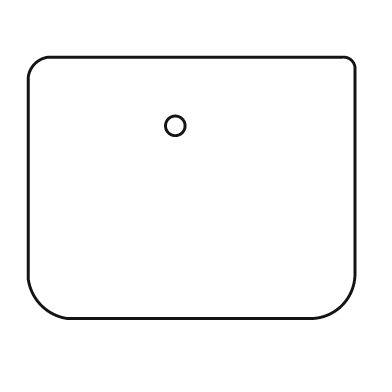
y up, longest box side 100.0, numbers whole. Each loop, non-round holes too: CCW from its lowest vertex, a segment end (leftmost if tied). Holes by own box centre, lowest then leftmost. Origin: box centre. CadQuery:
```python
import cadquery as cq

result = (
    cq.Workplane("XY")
    .moveTo(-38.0, -40.0)
    .lineTo(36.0, -40.0)
    .threePointArc((46.0, -36.0), (50.0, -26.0))
    .lineTo(50.0, 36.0)
    .threePointArc((49.0, 39.0), (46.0, 40.0))
    .lineTo(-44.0, 40.0)
    .threePointArc((-48.0, 38.0), (-50.0, 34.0))
    .lineTo(-50.0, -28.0)
    .threePointArc((-46.0, -36.0), (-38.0, -40.0))
    .close()
    .moveTo(-5.0, 19.0)
    .circle(3.0)
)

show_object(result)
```